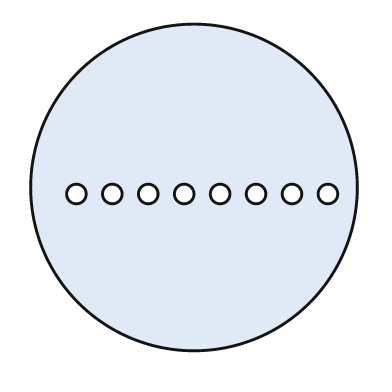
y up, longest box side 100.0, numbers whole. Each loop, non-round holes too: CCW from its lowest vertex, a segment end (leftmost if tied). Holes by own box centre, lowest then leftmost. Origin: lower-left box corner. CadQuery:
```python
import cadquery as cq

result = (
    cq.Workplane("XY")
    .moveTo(50.0, 50.0)
    .circle(50.0)
    .moveTo(14.0, 48.0)
    .circle(3.0)
    .moveTo(25.0, 48.0)
    .circle(3.0)
    .moveTo(36.0, 48.0)
    .circle(3.0)
    .moveTo(47.0, 48.0)
    .circle(3.0)
    .moveTo(58.0, 48.0)
    .circle(3.0)
    .moveTo(69.0, 48.0)
    .circle(3.0)
    .moveTo(80.0, 48.0)
    .circle(3.0)
    .moveTo(91.0, 48.0)
    .circle(3.0)
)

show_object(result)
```